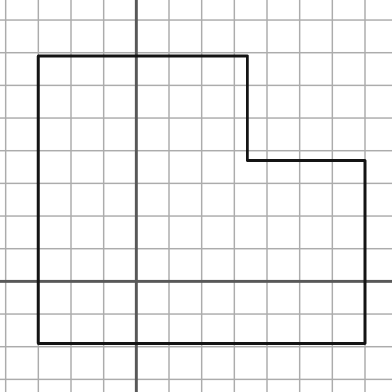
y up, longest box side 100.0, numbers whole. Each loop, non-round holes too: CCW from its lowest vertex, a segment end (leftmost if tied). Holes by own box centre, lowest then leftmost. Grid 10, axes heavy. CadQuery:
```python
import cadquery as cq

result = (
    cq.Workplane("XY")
    .moveTo(-30.0, -19.0)
    .lineTo(70.0, -19.0)
    .lineTo(70.0, 37.0)
    .lineTo(34.0, 37.0)
    .lineTo(34.0, 69.0)
    .lineTo(-30.0, 69.0)
    .close()
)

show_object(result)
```